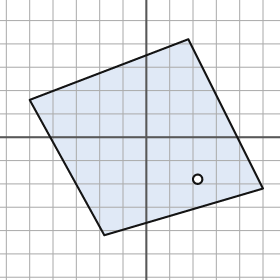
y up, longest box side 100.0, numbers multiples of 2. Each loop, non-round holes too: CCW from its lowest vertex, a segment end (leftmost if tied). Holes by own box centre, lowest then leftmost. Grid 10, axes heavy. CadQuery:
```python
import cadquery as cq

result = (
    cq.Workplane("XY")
    .moveTo(-18.0, -42.0)
    .lineTo(50.0, -22.0)
    .lineTo(18.0, 42.0)
    .lineTo(-50.0, 16.0)
    .close()
    .moveTo(22.0, -18.0)
    .circle(2.0)
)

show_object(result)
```